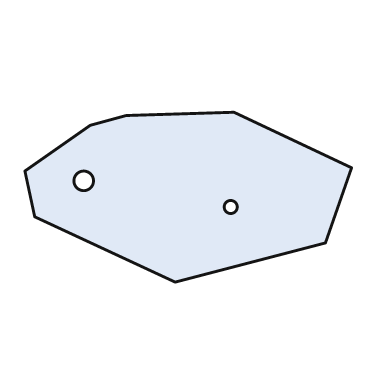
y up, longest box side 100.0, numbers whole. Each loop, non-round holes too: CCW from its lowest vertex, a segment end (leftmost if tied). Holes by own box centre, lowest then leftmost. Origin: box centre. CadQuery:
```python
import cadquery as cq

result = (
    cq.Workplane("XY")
    .moveTo(-4.0, -26.0)
    .lineTo(42.0, -14.0)
    .lineTo(50.0, 9.0)
    .lineTo(14.0, 26.0)
    .lineTo(-19.0, 25.0)
    .lineTo(-30.0, 22.0)
    .lineTo(-50.0, 8.0)
    .lineTo(-47.0, -6.0)
    .close()
    .moveTo(13.0, -3.0)
    .circle(2.0)
    .moveTo(-32.0, 5.0)
    .circle(3.0)
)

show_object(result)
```